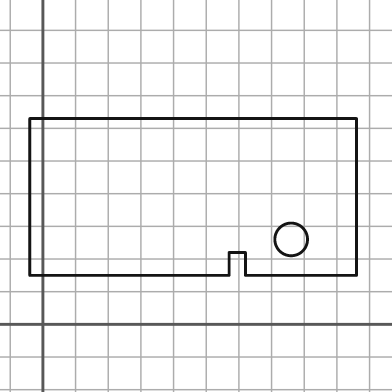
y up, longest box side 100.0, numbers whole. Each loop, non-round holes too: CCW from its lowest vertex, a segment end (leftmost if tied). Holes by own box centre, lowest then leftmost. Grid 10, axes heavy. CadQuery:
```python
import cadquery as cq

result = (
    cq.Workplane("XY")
    .moveTo(-4.0, 15.0)
    .lineTo(57.0, 15.0)
    .lineTo(57.0, 22.0)
    .lineTo(62.0, 22.0)
    .lineTo(62.0, 15.0)
    .lineTo(96.0, 15.0)
    .lineTo(96.0, 63.0)
    .lineTo(-4.0, 63.0)
    .close()
    .moveTo(76.0, 26.0)
    .circle(5.0)
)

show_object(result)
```